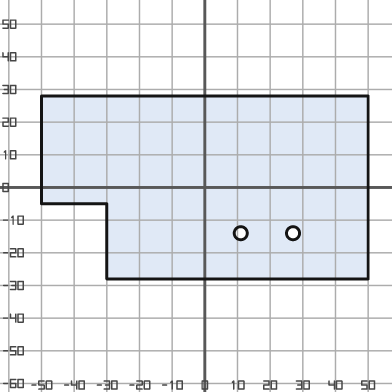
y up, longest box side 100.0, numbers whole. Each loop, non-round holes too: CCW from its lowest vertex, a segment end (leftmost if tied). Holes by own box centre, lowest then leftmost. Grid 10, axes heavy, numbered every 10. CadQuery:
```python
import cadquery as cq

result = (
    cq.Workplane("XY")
    .moveTo(-30.0, -28.0)
    .lineTo(50.0, -28.0)
    .lineTo(50.0, 28.0)
    .lineTo(-50.0, 28.0)
    .lineTo(-50.0, -5.0)
    .lineTo(-30.0, -5.0)
    .close()
    .moveTo(11.0, -14.0)
    .circle(2.0)
    .moveTo(27.0, -14.0)
    .circle(2.0)
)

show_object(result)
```